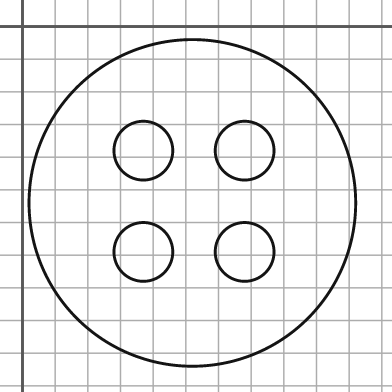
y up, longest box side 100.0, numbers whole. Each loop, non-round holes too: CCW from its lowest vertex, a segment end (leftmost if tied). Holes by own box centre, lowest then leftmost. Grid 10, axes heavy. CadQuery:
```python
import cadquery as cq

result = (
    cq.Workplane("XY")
    .moveTo(52.0, -54.0)
    .circle(50.0)
    .moveTo(37.0, -69.0)
    .circle(9.0)
    .moveTo(68.0, -69.0)
    .circle(9.0)
    .moveTo(37.0, -38.0)
    .circle(9.0)
    .moveTo(68.0, -38.0)
    .circle(9.0)
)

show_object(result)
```